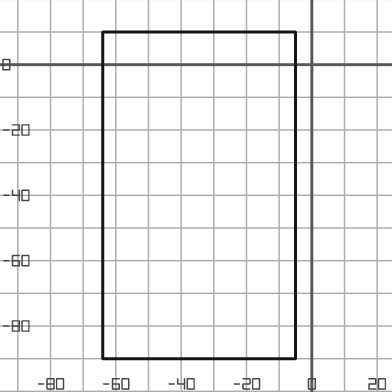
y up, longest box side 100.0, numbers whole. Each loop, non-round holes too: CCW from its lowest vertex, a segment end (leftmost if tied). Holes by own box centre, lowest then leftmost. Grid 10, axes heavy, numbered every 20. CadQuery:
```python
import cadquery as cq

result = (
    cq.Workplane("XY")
    .moveTo(-64.0, -90.0)
    .lineTo(-5.0, -90.0)
    .lineTo(-5.0, 10.0)
    .lineTo(-64.0, 10.0)
    .close()
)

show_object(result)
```